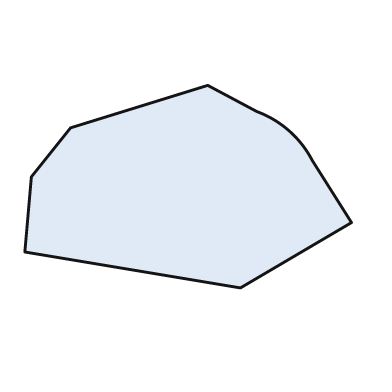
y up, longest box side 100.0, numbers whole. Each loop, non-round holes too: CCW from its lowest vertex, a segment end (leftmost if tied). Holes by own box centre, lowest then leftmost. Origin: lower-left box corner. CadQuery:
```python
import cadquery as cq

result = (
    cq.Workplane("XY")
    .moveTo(66.0, 0.0)
    .lineTo(100.0, 20.0)
    .lineTo(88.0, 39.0)
    .threePointArc((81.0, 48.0), (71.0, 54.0))
    .lineTo(56.0, 62.0)
    .lineTo(14.0, 49.0)
    .lineTo(2.0, 34.0)
    .lineTo(0.0, 11.0)
    .close()
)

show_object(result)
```